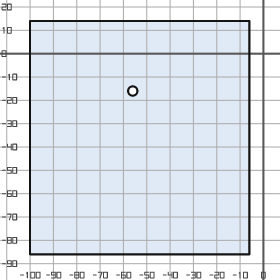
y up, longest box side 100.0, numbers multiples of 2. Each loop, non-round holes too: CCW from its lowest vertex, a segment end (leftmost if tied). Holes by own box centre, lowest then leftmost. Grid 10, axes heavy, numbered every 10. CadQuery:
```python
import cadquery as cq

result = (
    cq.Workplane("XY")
    .moveTo(-100.0, -86.0)
    .lineTo(-6.0, -86.0)
    .lineTo(-6.0, 14.0)
    .lineTo(-100.0, 14.0)
    .close()
    .moveTo(-56.0, -16.0)
    .circle(2.0)
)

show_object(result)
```